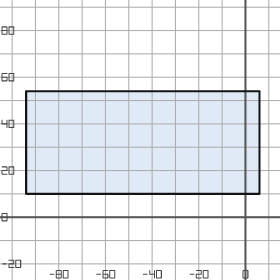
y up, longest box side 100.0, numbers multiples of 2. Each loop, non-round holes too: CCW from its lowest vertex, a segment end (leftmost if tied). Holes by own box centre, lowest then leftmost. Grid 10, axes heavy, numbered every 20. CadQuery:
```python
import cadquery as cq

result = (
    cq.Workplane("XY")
    .moveTo(-94.0, 10.0)
    .lineTo(6.0, 10.0)
    .lineTo(6.0, 54.0)
    .lineTo(-94.0, 54.0)
    .close()
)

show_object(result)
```